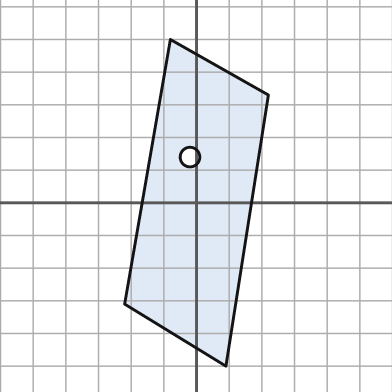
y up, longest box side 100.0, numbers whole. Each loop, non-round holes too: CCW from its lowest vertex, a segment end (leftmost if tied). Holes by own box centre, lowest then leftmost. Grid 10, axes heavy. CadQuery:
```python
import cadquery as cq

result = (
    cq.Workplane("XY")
    .moveTo(9.0, -50.0)
    .lineTo(22.0, 33.0)
    .lineTo(-8.0, 50.0)
    .lineTo(-22.0, -31.0)
    .close()
    .moveTo(-2.0, 14.0)
    .circle(3.0)
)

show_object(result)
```